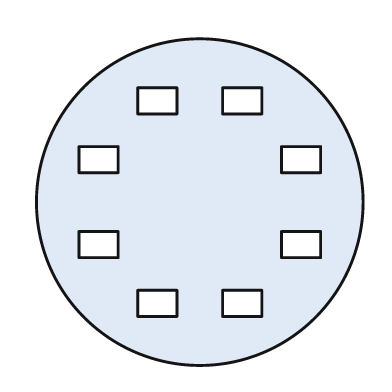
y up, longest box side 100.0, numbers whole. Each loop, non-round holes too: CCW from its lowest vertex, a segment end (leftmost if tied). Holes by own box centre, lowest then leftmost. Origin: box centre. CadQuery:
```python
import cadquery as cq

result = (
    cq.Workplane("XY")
    .moveTo(0.0, 0.0)
    .circle(50.0)
    .moveTo(-19.0, -35.0)
    .lineTo(-7.0, -35.0)
    .lineTo(-7.0, -27.0)
    .lineTo(-19.0, -27.0)
    .close()
    .moveTo(7.0, -35.0)
    .lineTo(19.0, -35.0)
    .lineTo(19.0, -27.0)
    .lineTo(7.0, -27.0)
    .close()
    .moveTo(-37.0, -17.0)
    .lineTo(-25.0, -17.0)
    .lineTo(-25.0, -9.0)
    .lineTo(-37.0, -9.0)
    .close()
    .moveTo(25.0, -17.0)
    .lineTo(37.0, -17.0)
    .lineTo(37.0, -9.0)
    .lineTo(25.0, -9.0)
    .close()
    .moveTo(-37.0, 9.0)
    .lineTo(-25.0, 9.0)
    .lineTo(-25.0, 17.0)
    .lineTo(-37.0, 17.0)
    .close()
    .moveTo(25.0, 9.0)
    .lineTo(37.0, 9.0)
    .lineTo(37.0, 17.0)
    .lineTo(25.0, 17.0)
    .close()
    .moveTo(-19.0, 27.0)
    .lineTo(-7.0, 27.0)
    .lineTo(-7.0, 35.0)
    .lineTo(-19.0, 35.0)
    .close()
    .moveTo(7.0, 27.0)
    .lineTo(19.0, 27.0)
    .lineTo(19.0, 35.0)
    .lineTo(7.0, 35.0)
    .close()
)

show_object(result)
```